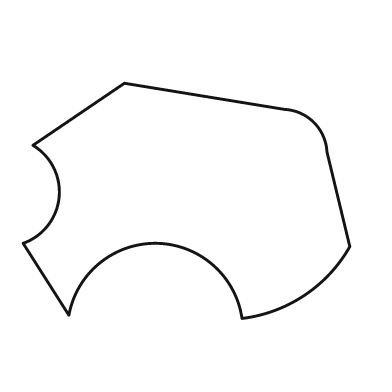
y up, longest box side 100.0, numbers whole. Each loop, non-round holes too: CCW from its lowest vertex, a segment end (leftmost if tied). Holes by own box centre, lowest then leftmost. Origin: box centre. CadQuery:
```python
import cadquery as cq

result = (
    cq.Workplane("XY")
    .moveTo(17.0, -36.0)
    .threePointArc((36.0, -29.0), (50.0, -14.0))
    .lineTo(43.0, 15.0)
    .threePointArc((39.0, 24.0), (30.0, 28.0))
    .lineTo(-19.0, 36.0)
    .lineTo(-47.0, 17.0)
    .threePointArc((-39.0, 1.0), (-50.0, -13.0))
    .lineTo(-36.0, -35.0)
    .threePointArc((-9.0, -13.0), (17.0, -36.0))
    .close()
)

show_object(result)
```